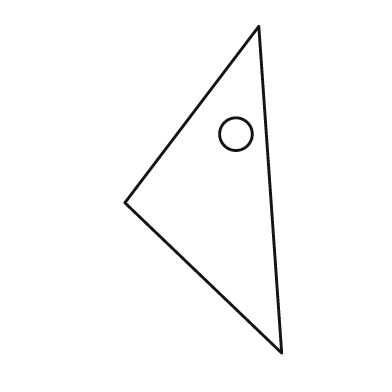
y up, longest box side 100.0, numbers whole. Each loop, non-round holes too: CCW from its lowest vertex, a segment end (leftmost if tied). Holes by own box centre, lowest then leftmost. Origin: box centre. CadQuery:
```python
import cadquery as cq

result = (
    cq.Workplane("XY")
    .moveTo(24.0, -50.0)
    .lineTo(17.0, 50.0)
    .lineTo(-24.0, -4.0)
    .close()
    .moveTo(10.0, 17.0)
    .circle(5.0)
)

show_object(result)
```